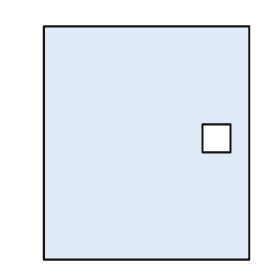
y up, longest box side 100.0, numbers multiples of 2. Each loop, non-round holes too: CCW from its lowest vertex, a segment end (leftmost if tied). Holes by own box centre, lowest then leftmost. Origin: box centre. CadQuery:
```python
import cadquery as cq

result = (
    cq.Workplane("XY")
    .moveTo(-44.0, -50.0)
    .lineTo(44.0, -50.0)
    .lineTo(44.0, 50.0)
    .lineTo(-44.0, 50.0)
    .close()
    .moveTo(24.0, -4.0)
    .lineTo(36.0, -4.0)
    .lineTo(36.0, 8.0)
    .lineTo(24.0, 8.0)
    .close()
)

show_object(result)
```